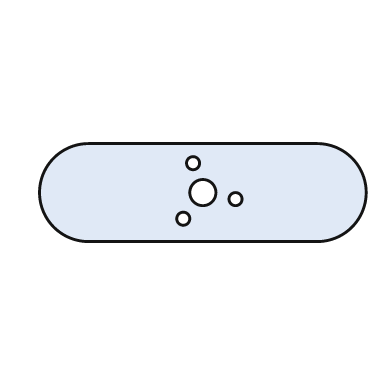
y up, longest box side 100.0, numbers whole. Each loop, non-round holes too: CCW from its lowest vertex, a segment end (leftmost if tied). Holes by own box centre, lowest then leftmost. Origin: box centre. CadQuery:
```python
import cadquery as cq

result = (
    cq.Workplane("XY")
    .moveTo(-35.0, -15.0)
    .lineTo(35.0, -15.0)
    .threePointArc((50.0, 0.0), (35.0, 15.0))
    .lineTo(-35.0, 15.0)
    .threePointArc((-50.0, 0.0), (-35.0, -15.0))
    .close()
    .moveTo(-6.0, -8.0)
    .circle(2.0)
    .moveTo(10.0, -2.0)
    .circle(2.0)
    .moveTo(0.0, 0.0)
    .circle(4.0)
    .moveTo(-3.0, 9.0)
    .circle(2.0)
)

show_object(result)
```